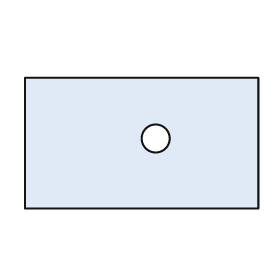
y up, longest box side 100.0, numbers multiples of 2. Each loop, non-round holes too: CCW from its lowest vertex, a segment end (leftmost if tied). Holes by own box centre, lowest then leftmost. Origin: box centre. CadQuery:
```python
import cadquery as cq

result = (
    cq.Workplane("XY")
    .moveTo(-50.0, -28.0)
    .lineTo(50.0, -28.0)
    .lineTo(50.0, 28.0)
    .lineTo(-50.0, 28.0)
    .close()
    .moveTo(6.0, 2.0)
    .circle(6.0)
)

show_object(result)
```